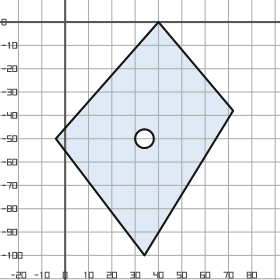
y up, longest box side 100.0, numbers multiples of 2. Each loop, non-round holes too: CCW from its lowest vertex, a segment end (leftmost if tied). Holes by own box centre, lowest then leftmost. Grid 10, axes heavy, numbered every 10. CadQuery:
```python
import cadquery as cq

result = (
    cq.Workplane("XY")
    .moveTo(34.0, -100.0)
    .lineTo(72.0, -38.0)
    .lineTo(40.0, 0.0)
    .lineTo(-4.0, -50.0)
    .close()
    .moveTo(34.0, -50.0)
    .circle(4.0)
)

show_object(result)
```